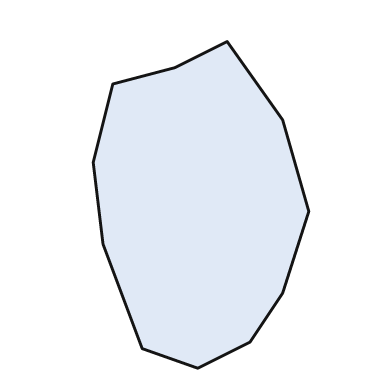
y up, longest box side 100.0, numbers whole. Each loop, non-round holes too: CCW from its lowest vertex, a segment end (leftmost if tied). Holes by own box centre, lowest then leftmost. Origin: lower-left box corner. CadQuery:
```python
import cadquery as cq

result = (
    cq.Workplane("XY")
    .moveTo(32.0, 0.0)
    .lineTo(48.0, 8.0)
    .lineTo(58.0, 23.0)
    .lineTo(66.0, 48.0)
    .lineTo(58.0, 76.0)
    .lineTo(41.0, 100.0)
    .lineTo(25.0, 92.0)
    .lineTo(6.0, 87.0)
    .lineTo(0.0, 63.0)
    .lineTo(3.0, 38.0)
    .lineTo(15.0, 6.0)
    .close()
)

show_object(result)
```